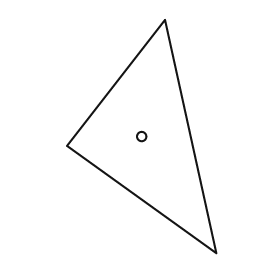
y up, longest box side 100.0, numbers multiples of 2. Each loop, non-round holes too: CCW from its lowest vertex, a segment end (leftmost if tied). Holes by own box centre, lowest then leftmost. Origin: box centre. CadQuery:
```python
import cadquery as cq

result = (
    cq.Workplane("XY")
    .moveTo(32.0, -50.0)
    .lineTo(10.0, 50.0)
    .lineTo(-32.0, -4.0)
    .close()
    .moveTo(0.0, 0.0)
    .circle(2.0)
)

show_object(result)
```